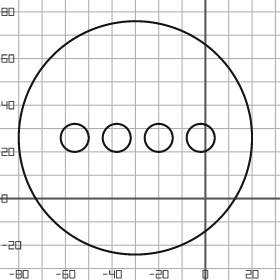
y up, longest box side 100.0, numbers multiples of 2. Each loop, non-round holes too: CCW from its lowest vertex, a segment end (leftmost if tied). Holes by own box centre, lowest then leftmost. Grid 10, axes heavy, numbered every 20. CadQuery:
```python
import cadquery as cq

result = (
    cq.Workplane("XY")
    .moveTo(-30.0, 26.0)
    .circle(50.0)
    .moveTo(-56.0, 26.0)
    .circle(6.0)
    .moveTo(-38.0, 26.0)
    .circle(6.0)
    .moveTo(-20.0, 26.0)
    .circle(6.0)
    .moveTo(-2.0, 26.0)
    .circle(6.0)
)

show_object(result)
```